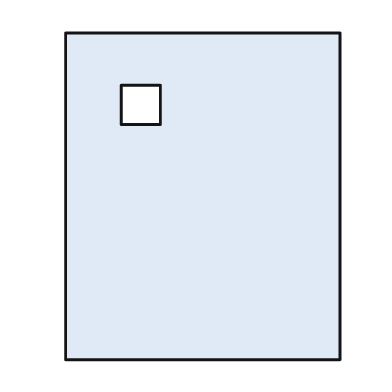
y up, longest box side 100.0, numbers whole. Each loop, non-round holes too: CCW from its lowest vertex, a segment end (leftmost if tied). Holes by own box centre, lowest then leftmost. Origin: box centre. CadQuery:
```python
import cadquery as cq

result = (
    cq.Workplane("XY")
    .moveTo(-42.0, -50.0)
    .lineTo(42.0, -50.0)
    .lineTo(42.0, 50.0)
    .lineTo(-42.0, 50.0)
    .close()
    .moveTo(-25.0, 22.0)
    .lineTo(-13.0, 22.0)
    .lineTo(-13.0, 34.0)
    .lineTo(-25.0, 34.0)
    .close()
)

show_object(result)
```